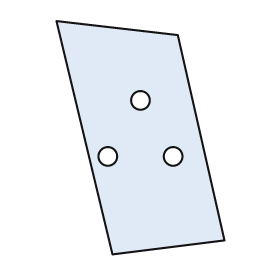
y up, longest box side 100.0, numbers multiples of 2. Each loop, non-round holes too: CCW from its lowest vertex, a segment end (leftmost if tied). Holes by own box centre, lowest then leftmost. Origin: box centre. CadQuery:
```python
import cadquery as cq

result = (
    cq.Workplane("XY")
    .moveTo(-12.0, -50.0)
    .lineTo(36.0, -44.0)
    .lineTo(16.0, 44.0)
    .lineTo(-36.0, 50.0)
    .close()
    .moveTo(-14.0, -8.0)
    .circle(4.0)
    .moveTo(14.0, -8.0)
    .circle(4.0)
    .moveTo(0.0, 16.0)
    .circle(4.0)
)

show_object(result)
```